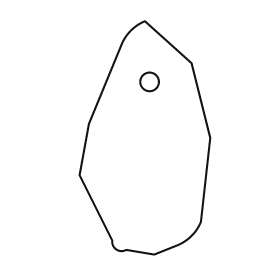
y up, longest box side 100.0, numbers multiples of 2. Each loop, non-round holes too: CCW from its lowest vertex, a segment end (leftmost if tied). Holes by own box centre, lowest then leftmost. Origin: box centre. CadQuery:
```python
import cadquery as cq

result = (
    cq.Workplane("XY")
    .moveTo(4.0, -50.0)
    .lineTo(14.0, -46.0)
    .threePointArc((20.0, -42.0), (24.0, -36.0))
    .lineTo(28.0, 0.0)
    .lineTo(20.0, 32.0)
    .lineTo(0.0, 50.0)
    .threePointArc((-6.0, 46.0), (-10.0, 40.0))
    .lineTo(-24.0, 6.0)
    .lineTo(-28.0, -16.0)
    .lineTo(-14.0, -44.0)
    .threePointArc((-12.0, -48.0), (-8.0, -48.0))
    .close()
    .moveTo(2.0, 24.0)
    .circle(4.0)
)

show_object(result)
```